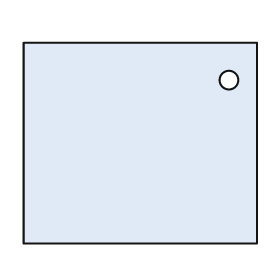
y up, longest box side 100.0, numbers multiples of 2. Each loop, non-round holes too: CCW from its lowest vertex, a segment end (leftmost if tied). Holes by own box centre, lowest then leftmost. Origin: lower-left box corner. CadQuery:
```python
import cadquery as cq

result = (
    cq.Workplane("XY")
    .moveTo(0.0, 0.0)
    .lineTo(100.0, 0.0)
    .lineTo(100.0, 86.0)
    .lineTo(0.0, 86.0)
    .close()
    .moveTo(88.0, 70.0)
    .circle(4.0)
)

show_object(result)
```